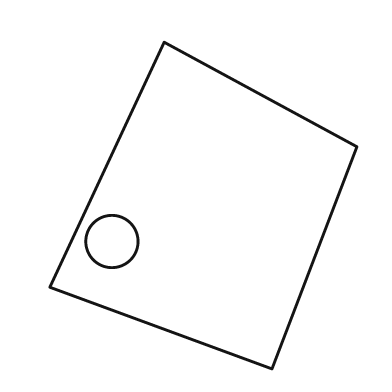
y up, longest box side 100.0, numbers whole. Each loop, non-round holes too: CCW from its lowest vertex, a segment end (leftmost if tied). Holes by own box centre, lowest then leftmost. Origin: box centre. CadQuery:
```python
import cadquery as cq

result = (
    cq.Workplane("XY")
    .moveTo(21.0, -50.0)
    .lineTo(47.0, 18.0)
    .lineTo(-12.0, 50.0)
    .lineTo(-47.0, -25.0)
    .close()
    .moveTo(-28.0, -11.0)
    .circle(8.0)
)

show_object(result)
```